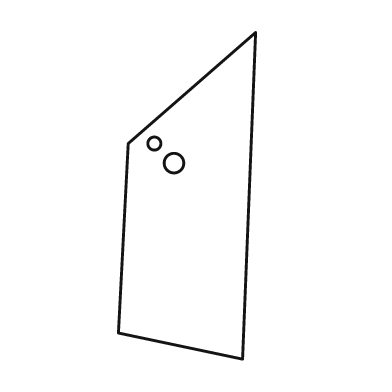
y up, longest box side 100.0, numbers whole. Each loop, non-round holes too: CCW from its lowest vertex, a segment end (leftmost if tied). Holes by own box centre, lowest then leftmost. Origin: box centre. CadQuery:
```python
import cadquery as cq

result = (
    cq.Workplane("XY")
    .moveTo(17.0, -50.0)
    .lineTo(21.0, 50.0)
    .lineTo(-18.0, 16.0)
    .lineTo(-21.0, -42.0)
    .close()
    .moveTo(-4.0, 10.0)
    .circle(3.0)
    .moveTo(-10.0, 16.0)
    .circle(2.0)
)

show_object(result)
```